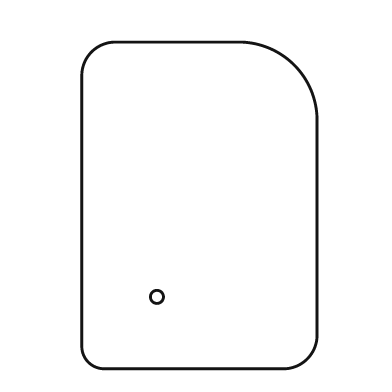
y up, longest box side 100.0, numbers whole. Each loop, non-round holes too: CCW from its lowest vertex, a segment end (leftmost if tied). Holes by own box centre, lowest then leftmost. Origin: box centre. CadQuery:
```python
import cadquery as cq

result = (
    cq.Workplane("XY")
    .moveTo(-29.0, -50.0)
    .lineTo(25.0, -50.0)
    .threePointArc((33.0, -47.0), (36.0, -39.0))
    .lineTo(36.0, 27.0)
    .threePointArc((29.0, 43.0), (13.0, 50.0))
    .lineTo(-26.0, 50.0)
    .threePointArc((-33.0, 47.0), (-36.0, 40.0))
    .lineTo(-36.0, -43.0)
    .threePointArc((-34.0, -48.0), (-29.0, -50.0))
    .close()
    .moveTo(-13.0, -28.0)
    .circle(2.0)
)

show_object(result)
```